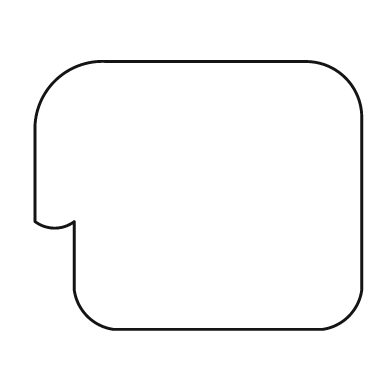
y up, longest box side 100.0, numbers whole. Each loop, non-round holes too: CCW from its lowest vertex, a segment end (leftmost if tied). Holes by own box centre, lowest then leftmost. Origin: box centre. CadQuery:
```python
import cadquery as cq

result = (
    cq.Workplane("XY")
    .moveTo(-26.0, -41.0)
    .lineTo(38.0, -41.0)
    .threePointArc((46.0, -37.0), (50.0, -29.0))
    .lineTo(50.0, 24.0)
    .threePointArc((45.0, 36.0), (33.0, 41.0))
    .lineTo(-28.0, 41.0)
    .threePointArc((-44.0, 35.0), (-50.0, 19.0))
    .lineTo(-50.0, -8.0)
    .threePointArc((-44.0, -10.0), (-38.0, -8.0))
    .lineTo(-38.0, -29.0)
    .threePointArc((-34.0, -37.0), (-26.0, -41.0))
    .close()
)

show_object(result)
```